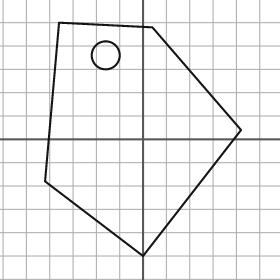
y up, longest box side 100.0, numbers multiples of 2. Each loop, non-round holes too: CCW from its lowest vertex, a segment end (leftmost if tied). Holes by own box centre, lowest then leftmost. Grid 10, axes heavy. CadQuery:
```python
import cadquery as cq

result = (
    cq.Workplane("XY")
    .moveTo(0.0, -50.0)
    .lineTo(42.0, 4.0)
    .lineTo(4.0, 48.0)
    .lineTo(-36.0, 50.0)
    .lineTo(-42.0, -18.0)
    .close()
    .moveTo(-16.0, 36.0)
    .circle(6.0)
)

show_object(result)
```